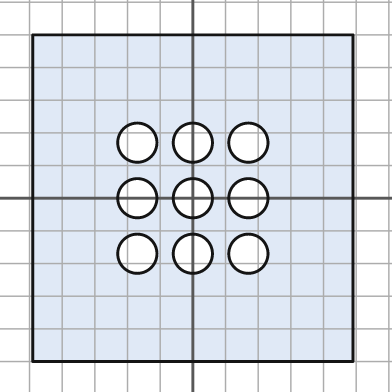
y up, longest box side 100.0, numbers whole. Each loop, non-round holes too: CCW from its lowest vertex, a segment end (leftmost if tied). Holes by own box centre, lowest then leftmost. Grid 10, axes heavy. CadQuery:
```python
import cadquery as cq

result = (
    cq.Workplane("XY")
    .moveTo(-49.0, -50.0)
    .lineTo(49.0, -50.0)
    .lineTo(49.0, 50.0)
    .lineTo(-49.0, 50.0)
    .close()
    .moveTo(-17.0, -17.0)
    .circle(6.0)
    .moveTo(0.0, -17.0)
    .circle(6.0)
    .moveTo(17.0, -17.0)
    .circle(6.0)
    .moveTo(-17.0, 0.0)
    .circle(6.0)
    .moveTo(0.0, 0.0)
    .circle(6.0)
    .moveTo(17.0, 0.0)
    .circle(6.0)
    .moveTo(-17.0, 17.0)
    .circle(6.0)
    .moveTo(0.0, 17.0)
    .circle(6.0)
    .moveTo(17.0, 17.0)
    .circle(6.0)
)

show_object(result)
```